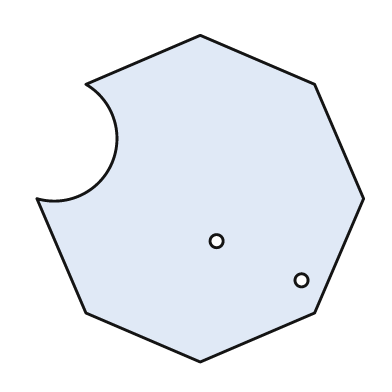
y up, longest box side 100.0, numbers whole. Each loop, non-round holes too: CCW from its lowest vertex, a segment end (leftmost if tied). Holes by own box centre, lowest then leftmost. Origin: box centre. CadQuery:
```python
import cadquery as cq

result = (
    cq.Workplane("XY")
    .moveTo(0.0, -50.0)
    .lineTo(35.0, -35.0)
    .lineTo(50.0, 0.0)
    .lineTo(35.0, 35.0)
    .lineTo(0.0, 50.0)
    .lineTo(-35.0, 35.0)
    .threePointArc((-27.0, 11.0), (-50.0, 0.0))
    .lineTo(-35.0, -35.0)
    .close()
    .moveTo(31.0, -25.0)
    .circle(2.0)
    .moveTo(5.0, -13.0)
    .circle(2.0)
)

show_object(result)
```